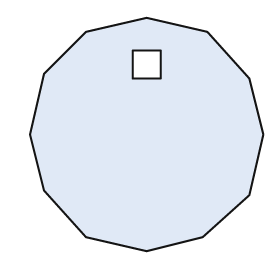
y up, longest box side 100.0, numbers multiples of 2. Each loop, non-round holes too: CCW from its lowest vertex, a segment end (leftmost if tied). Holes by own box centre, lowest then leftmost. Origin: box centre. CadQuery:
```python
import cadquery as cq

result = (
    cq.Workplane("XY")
    .moveTo(0.0, -50.0)
    .lineTo(24.0, -44.0)
    .lineTo(44.0, -26.0)
    .lineTo(50.0, 0.0)
    .lineTo(44.0, 24.0)
    .lineTo(26.0, 44.0)
    .lineTo(0.0, 50.0)
    .lineTo(-26.0, 44.0)
    .lineTo(-44.0, 26.0)
    .lineTo(-50.0, 0.0)
    .lineTo(-44.0, -24.0)
    .lineTo(-26.0, -44.0)
    .close()
    .moveTo(-6.0, 24.0)
    .lineTo(6.0, 24.0)
    .lineTo(6.0, 36.0)
    .lineTo(-6.0, 36.0)
    .close()
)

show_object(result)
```